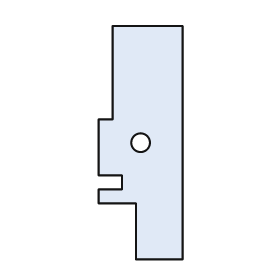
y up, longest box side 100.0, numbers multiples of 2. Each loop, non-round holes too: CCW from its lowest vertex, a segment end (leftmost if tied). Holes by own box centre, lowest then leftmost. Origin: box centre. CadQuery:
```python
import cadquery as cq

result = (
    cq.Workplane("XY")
    .moveTo(-2.0, -50.0)
    .lineTo(18.0, -50.0)
    .lineTo(18.0, 50.0)
    .lineTo(-12.0, 50.0)
    .lineTo(-12.0, 10.0)
    .lineTo(-18.0, 10.0)
    .lineTo(-18.0, -14.0)
    .lineTo(-8.0, -14.0)
    .lineTo(-8.0, -20.0)
    .lineTo(-18.0, -20.0)
    .lineTo(-18.0, -26.0)
    .lineTo(-2.0, -26.0)
    .close()
    .moveTo(0.0, 0.0)
    .circle(4.0)
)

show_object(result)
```